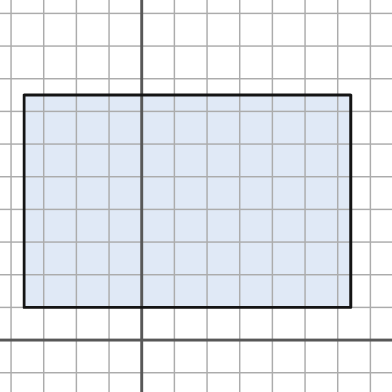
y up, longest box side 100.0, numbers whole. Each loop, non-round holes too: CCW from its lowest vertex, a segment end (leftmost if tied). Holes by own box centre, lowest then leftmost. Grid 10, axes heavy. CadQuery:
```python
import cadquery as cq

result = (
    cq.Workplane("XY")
    .moveTo(-36.0, 10.0)
    .lineTo(64.0, 10.0)
    .lineTo(64.0, 75.0)
    .lineTo(-36.0, 75.0)
    .close()
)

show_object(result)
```